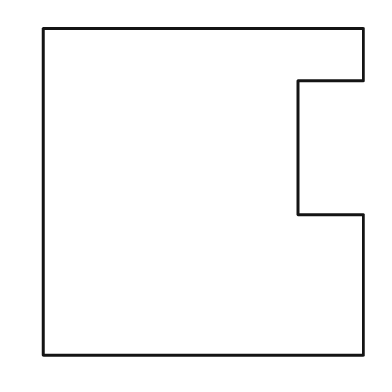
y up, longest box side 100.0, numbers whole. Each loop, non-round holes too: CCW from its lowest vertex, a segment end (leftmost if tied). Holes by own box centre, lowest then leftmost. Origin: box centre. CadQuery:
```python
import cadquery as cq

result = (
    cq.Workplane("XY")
    .moveTo(-49.0, -50.0)
    .lineTo(49.0, -50.0)
    .lineTo(49.0, -7.0)
    .lineTo(29.0, -7.0)
    .lineTo(29.0, 34.0)
    .lineTo(49.0, 34.0)
    .lineTo(49.0, 50.0)
    .lineTo(-49.0, 50.0)
    .close()
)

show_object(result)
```